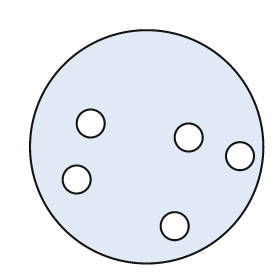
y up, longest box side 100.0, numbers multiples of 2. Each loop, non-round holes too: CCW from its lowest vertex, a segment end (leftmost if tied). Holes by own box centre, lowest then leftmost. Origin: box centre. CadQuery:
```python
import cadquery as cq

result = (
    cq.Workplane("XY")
    .moveTo(0.0, 0.0)
    .circle(50.0)
    .moveTo(12.0, -34.0)
    .circle(6.0)
    .moveTo(-30.0, -14.0)
    .circle(6.0)
    .moveTo(40.0, -4.0)
    .circle(6.0)
    .moveTo(18.0, 4.0)
    .circle(6.0)
    .moveTo(-24.0, 10.0)
    .circle(6.0)
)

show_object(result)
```